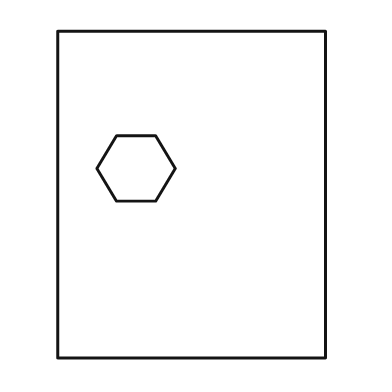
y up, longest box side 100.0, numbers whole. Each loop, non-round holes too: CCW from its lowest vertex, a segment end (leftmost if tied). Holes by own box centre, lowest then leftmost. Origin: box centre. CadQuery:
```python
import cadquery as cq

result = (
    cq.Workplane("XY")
    .moveTo(-41.0, -50.0)
    .lineTo(41.0, -50.0)
    .lineTo(41.0, 50.0)
    .lineTo(-41.0, 50.0)
    .close()
    .moveTo(-23.0, -2.0)
    .lineTo(-11.0, -2.0)
    .lineTo(-5.0, 8.0)
    .lineTo(-11.0, 18.0)
    .lineTo(-23.0, 18.0)
    .lineTo(-29.0, 8.0)
    .close()
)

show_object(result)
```